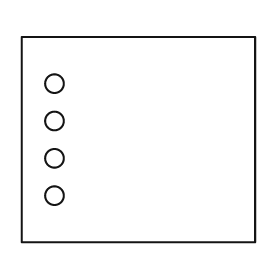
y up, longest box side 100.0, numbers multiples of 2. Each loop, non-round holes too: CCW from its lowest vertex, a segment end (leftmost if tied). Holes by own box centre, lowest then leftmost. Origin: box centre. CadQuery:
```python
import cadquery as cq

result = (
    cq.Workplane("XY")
    .moveTo(-50.0, -44.0)
    .lineTo(50.0, -44.0)
    .lineTo(50.0, 44.0)
    .lineTo(-50.0, 44.0)
    .close()
    .moveTo(-36.0, -24.0)
    .circle(4.0)
    .moveTo(-36.0, -8.0)
    .circle(4.0)
    .moveTo(-36.0, 8.0)
    .circle(4.0)
    .moveTo(-36.0, 24.0)
    .circle(4.0)
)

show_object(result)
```